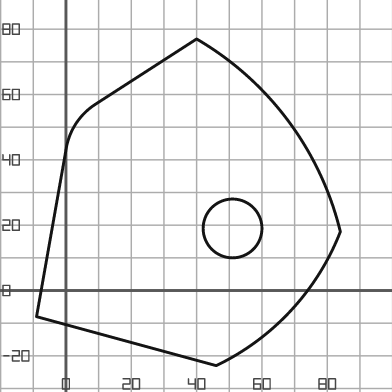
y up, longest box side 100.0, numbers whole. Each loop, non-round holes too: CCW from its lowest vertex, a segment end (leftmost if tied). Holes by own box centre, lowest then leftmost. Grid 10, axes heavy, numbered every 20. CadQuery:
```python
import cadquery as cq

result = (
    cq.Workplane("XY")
    .moveTo(46.0, -23.0)
    .threePointArc((69.0, -6.0), (84.0, 18.0))
    .threePointArc((68.0, 52.0), (40.0, 77.0))
    .lineTo(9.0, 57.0)
    .threePointArc((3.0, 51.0), (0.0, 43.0))
    .lineTo(-9.0, -8.0)
    .close()
    .moveTo(51.0, 19.0)
    .circle(9.0)
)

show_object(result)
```